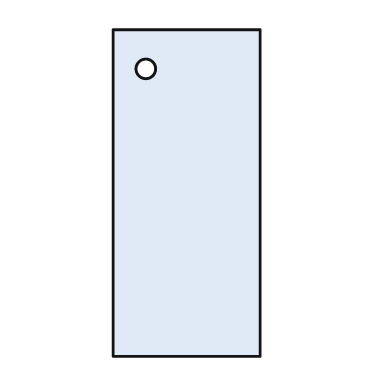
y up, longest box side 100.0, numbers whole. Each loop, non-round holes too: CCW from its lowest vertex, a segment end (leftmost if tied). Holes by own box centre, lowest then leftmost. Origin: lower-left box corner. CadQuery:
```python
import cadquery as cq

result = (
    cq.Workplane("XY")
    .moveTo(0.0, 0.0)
    .lineTo(45.0, 0.0)
    .lineTo(45.0, 100.0)
    .lineTo(0.0, 100.0)
    .close()
    .moveTo(10.0, 88.0)
    .circle(3.0)
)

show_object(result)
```